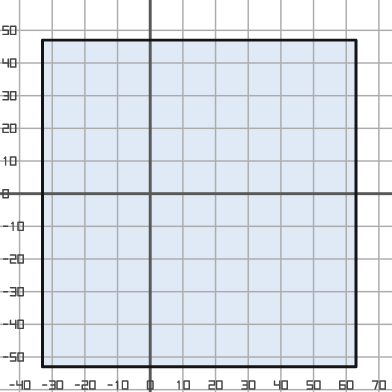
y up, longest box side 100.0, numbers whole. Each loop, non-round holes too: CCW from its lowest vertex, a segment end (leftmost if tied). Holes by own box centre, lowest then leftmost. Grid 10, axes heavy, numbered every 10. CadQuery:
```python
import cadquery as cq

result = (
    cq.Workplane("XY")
    .moveTo(-33.0, -53.0)
    .lineTo(63.0, -53.0)
    .lineTo(63.0, 47.0)
    .lineTo(-33.0, 47.0)
    .close()
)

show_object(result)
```